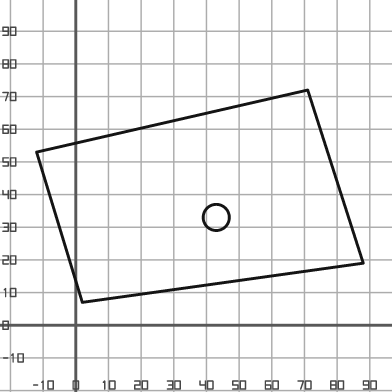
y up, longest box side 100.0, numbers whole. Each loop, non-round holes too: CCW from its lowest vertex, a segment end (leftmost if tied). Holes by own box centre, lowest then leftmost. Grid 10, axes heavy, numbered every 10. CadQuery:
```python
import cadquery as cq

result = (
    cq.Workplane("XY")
    .moveTo(2.0, 7.0)
    .lineTo(88.0, 19.0)
    .lineTo(71.0, 72.0)
    .lineTo(-12.0, 53.0)
    .close()
    .moveTo(43.0, 33.0)
    .circle(4.0)
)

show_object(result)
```